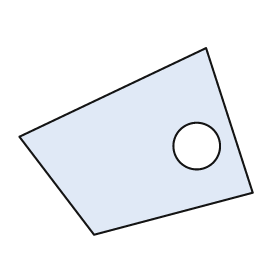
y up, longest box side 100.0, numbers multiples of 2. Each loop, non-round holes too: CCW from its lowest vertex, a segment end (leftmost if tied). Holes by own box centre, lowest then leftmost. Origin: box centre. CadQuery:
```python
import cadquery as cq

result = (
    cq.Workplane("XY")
    .moveTo(-18.0, -40.0)
    .lineTo(50.0, -22.0)
    .lineTo(30.0, 40.0)
    .lineTo(-50.0, 2.0)
    .close()
    .moveTo(26.0, -2.0)
    .circle(10.0)
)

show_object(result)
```